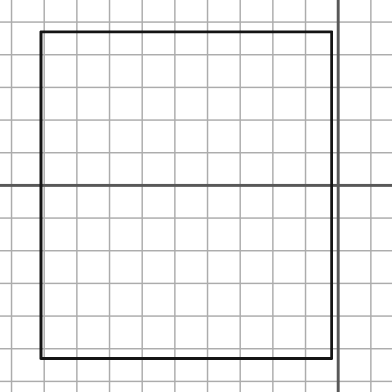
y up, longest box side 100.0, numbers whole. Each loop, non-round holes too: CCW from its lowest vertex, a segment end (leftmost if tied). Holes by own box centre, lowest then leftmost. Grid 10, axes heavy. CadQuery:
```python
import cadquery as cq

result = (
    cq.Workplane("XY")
    .moveTo(-91.0, -53.0)
    .lineTo(-2.0, -53.0)
    .lineTo(-2.0, 47.0)
    .lineTo(-91.0, 47.0)
    .close()
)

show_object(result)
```